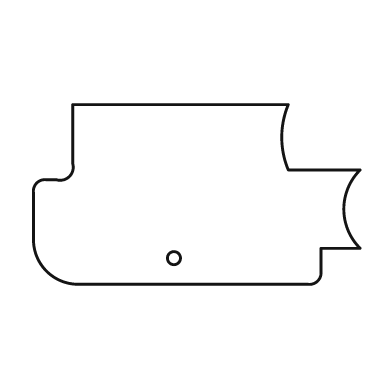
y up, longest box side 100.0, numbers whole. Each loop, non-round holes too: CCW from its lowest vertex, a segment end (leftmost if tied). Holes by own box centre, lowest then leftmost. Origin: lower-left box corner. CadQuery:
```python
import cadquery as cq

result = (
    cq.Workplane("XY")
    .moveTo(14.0, 0.0)
    .lineTo(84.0, 0.0)
    .threePointArc((87.0, 1.0), (88.0, 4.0))
    .lineTo(88.0, 11.0)
    .lineTo(100.0, 11.0)
    .threePointArc((95.0, 23.0), (100.0, 35.0))
    .lineTo(78.0, 35.0)
    .threePointArc((76.0, 45.0), (78.0, 55.0))
    .lineTo(12.0, 55.0)
    .lineTo(12.0, 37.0)
    .threePointArc((11.0, 33.0), (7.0, 32.0))
    .lineTo(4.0, 32.0)
    .threePointArc((1.0, 31.0), (0.0, 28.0))
    .lineTo(0.0, 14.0)
    .threePointArc((4.0, 4.0), (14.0, 0.0))
    .close()
    .moveTo(43.0, 8.0)
    .circle(2.0)
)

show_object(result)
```